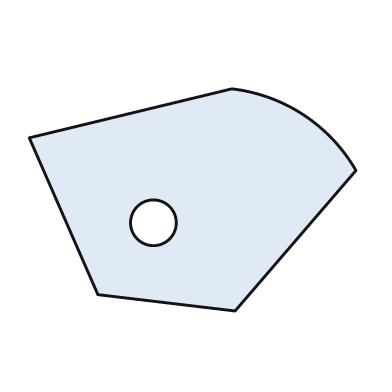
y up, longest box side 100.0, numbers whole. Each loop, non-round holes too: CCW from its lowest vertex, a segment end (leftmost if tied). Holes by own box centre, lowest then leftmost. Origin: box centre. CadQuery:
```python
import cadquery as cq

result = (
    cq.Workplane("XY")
    .moveTo(13.0, -34.0)
    .lineTo(50.0, 9.0)
    .threePointArc((34.0, 26.0), (12.0, 34.0))
    .lineTo(-50.0, 19.0)
    .lineTo(-29.0, -29.0)
    .close()
    .moveTo(-12.0, -7.0)
    .circle(7.0)
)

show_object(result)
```